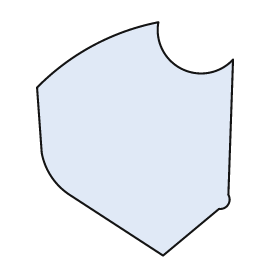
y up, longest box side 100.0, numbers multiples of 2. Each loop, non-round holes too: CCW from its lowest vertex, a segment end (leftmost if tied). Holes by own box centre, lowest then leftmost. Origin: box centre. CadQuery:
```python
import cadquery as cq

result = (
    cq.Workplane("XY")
    .moveTo(12.0, -50.0)
    .lineTo(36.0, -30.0)
    .threePointArc((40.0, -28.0), (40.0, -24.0))
    .lineTo(42.0, 34.0)
    .threePointArc((20.0, 30.0), (10.0, 50.0))
    .threePointArc((-18.0, 40.0), (-42.0, 22.0))
    .lineTo(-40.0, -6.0)
    .threePointArc((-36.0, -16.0), (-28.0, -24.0))
    .close()
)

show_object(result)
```